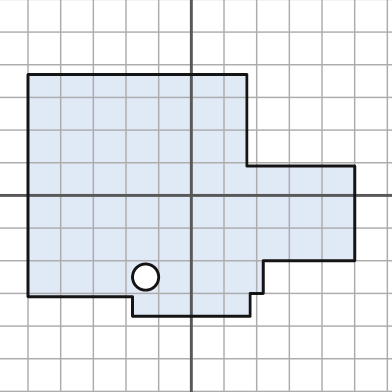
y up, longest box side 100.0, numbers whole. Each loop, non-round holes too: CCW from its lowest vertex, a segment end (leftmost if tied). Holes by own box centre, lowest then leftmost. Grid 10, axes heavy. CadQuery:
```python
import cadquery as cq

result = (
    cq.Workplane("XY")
    .moveTo(-18.0, -37.0)
    .lineTo(18.0, -37.0)
    .lineTo(18.0, -30.0)
    .lineTo(22.0, -30.0)
    .lineTo(22.0, -20.0)
    .lineTo(50.0, -20.0)
    .lineTo(50.0, 9.0)
    .lineTo(17.0, 9.0)
    .lineTo(17.0, 37.0)
    .lineTo(-50.0, 37.0)
    .lineTo(-50.0, -31.0)
    .lineTo(-18.0, -31.0)
    .close()
    .moveTo(-14.0, -25.0)
    .circle(4.0)
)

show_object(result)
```